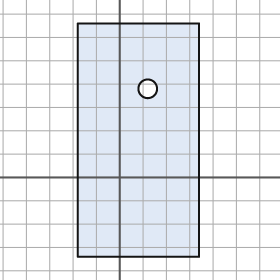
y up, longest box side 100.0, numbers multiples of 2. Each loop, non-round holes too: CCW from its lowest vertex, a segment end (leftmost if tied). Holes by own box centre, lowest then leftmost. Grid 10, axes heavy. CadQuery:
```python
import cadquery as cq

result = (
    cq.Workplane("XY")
    .moveTo(-18.0, -34.0)
    .lineTo(34.0, -34.0)
    .lineTo(34.0, 66.0)
    .lineTo(-18.0, 66.0)
    .close()
    .moveTo(12.0, 38.0)
    .circle(4.0)
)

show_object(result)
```